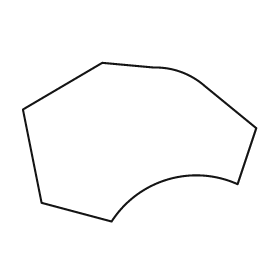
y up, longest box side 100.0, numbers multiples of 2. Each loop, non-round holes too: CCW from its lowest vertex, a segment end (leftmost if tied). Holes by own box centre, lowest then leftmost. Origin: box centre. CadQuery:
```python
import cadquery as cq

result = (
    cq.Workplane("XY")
    .moveTo(-12.0, -34.0)
    .threePointArc((12.0, -16.0), (42.0, -18.0))
    .lineTo(50.0, 6.0)
    .lineTo(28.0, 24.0)
    .threePointArc((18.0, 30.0), (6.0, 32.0))
    .lineTo(-16.0, 34.0)
    .lineTo(-50.0, 14.0)
    .lineTo(-42.0, -26.0)
    .close()
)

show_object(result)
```